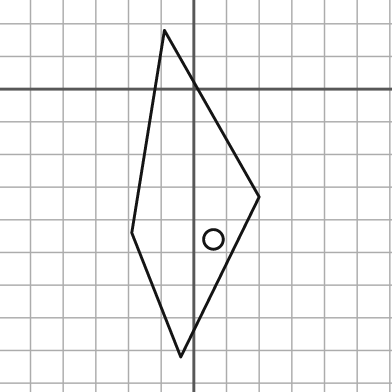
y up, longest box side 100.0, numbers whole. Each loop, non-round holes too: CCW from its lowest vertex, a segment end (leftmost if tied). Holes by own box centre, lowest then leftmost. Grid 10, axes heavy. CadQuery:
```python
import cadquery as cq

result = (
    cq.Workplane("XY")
    .moveTo(-4.0, -82.0)
    .lineTo(20.0, -33.0)
    .lineTo(-9.0, 18.0)
    .lineTo(-19.0, -44.0)
    .close()
    .moveTo(6.0, -46.0)
    .circle(3.0)
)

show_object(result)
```